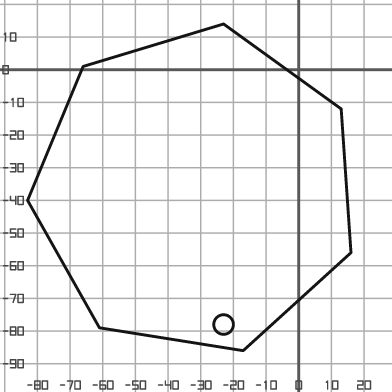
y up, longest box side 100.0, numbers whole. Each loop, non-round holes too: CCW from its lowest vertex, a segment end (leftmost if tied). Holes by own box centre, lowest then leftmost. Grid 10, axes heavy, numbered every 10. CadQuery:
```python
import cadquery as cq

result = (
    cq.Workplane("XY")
    .moveTo(-17.0, -86.0)
    .lineTo(16.0, -56.0)
    .lineTo(13.0, -12.0)
    .lineTo(-23.0, 14.0)
    .lineTo(-66.0, 1.0)
    .lineTo(-83.0, -40.0)
    .lineTo(-61.0, -79.0)
    .close()
    .moveTo(-23.0, -78.0)
    .circle(3.0)
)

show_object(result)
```